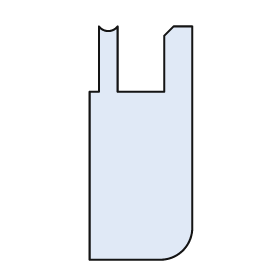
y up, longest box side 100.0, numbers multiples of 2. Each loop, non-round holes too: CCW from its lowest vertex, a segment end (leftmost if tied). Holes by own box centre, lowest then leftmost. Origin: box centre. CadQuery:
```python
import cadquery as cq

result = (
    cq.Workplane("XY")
    .moveTo(-22.0, -50.0)
    .lineTo(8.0, -50.0)
    .threePointArc((18.0, -46.0), (22.0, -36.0))
    .lineTo(22.0, 50.0)
    .lineTo(14.0, 50.0)
    .lineTo(10.0, 46.0)
    .lineTo(10.0, 22.0)
    .lineTo(-10.0, 22.0)
    .lineTo(-10.0, 50.0)
    .threePointArc((-14.0, 48.0), (-18.0, 50.0))
    .lineTo(-18.0, 22.0)
    .lineTo(-22.0, 22.0)
    .close()
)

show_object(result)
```